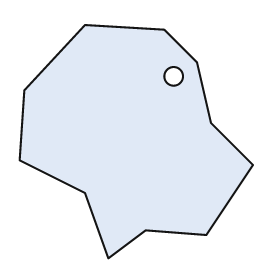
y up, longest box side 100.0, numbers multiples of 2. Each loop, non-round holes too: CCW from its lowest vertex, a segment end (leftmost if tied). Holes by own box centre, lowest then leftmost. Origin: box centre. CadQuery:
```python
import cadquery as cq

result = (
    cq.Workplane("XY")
    .moveTo(-12.0, -50.0)
    .lineTo(4.0, -38.0)
    .lineTo(30.0, -40.0)
    .lineTo(50.0, -10.0)
    .lineTo(32.0, 8.0)
    .lineTo(26.0, 34.0)
    .lineTo(12.0, 48.0)
    .lineTo(-22.0, 50.0)
    .lineTo(-48.0, 22.0)
    .lineTo(-50.0, -8.0)
    .lineTo(-22.0, -22.0)
    .close()
    .moveTo(16.0, 28.0)
    .circle(4.0)
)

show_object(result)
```